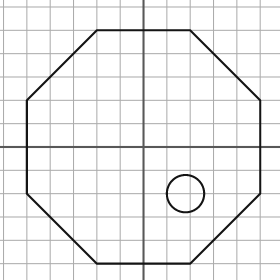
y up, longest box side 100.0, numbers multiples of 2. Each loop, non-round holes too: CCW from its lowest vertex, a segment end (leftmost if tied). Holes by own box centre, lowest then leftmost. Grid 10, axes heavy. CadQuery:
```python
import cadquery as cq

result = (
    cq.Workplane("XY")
    .moveTo(-20.0, -50.0)
    .lineTo(20.0, -50.0)
    .lineTo(50.0, -20.0)
    .lineTo(50.0, 20.0)
    .lineTo(20.0, 50.0)
    .lineTo(-20.0, 50.0)
    .lineTo(-50.0, 20.0)
    .lineTo(-50.0, -20.0)
    .close()
    .moveTo(18.0, -20.0)
    .circle(8.0)
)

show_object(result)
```